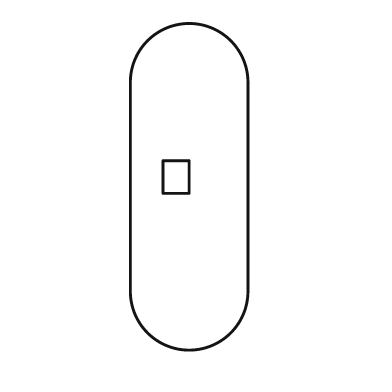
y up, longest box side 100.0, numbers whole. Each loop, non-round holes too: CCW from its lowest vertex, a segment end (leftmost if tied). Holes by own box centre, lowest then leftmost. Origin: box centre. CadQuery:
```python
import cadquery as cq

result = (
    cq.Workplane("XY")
    .moveTo(-18.0, -32.0)
    .threePointArc((0.0, -50.0), (18.0, -32.0))
    .lineTo(18.0, 32.0)
    .threePointArc((0.0, 50.0), (-18.0, 32.0))
    .close()
    .moveTo(-8.0, -2.0)
    .lineTo(0.0, -2.0)
    .lineTo(0.0, 8.0)
    .lineTo(-8.0, 8.0)
    .close()
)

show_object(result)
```